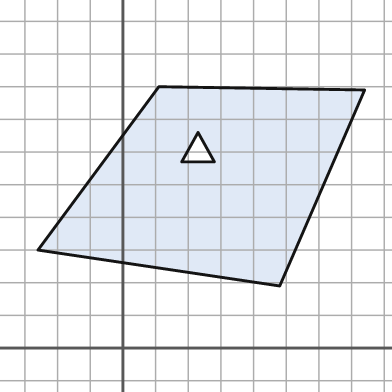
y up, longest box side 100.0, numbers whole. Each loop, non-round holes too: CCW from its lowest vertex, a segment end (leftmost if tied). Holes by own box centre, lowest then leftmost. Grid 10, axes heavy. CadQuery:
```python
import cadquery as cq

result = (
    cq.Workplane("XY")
    .moveTo(48.0, 19.0)
    .lineTo(74.0, 79.0)
    .lineTo(11.0, 80.0)
    .lineTo(-26.0, 30.0)
    .close()
    .moveTo(18.0, 57.0)
    .lineTo(28.0, 57.0)
    .lineTo(23.0, 66.0)
    .close()
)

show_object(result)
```